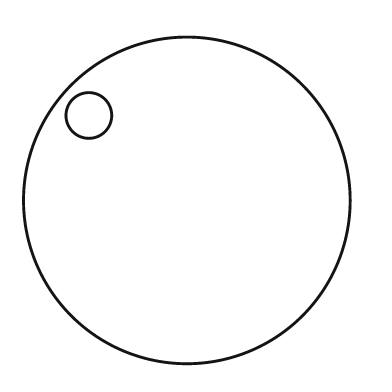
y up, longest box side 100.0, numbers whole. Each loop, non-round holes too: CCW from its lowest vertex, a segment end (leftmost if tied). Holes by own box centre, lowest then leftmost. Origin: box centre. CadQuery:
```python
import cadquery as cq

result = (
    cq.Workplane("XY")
    .moveTo(0.0, 0.0)
    .circle(50.0)
    .moveTo(-30.0, 26.0)
    .circle(7.0)
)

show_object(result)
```